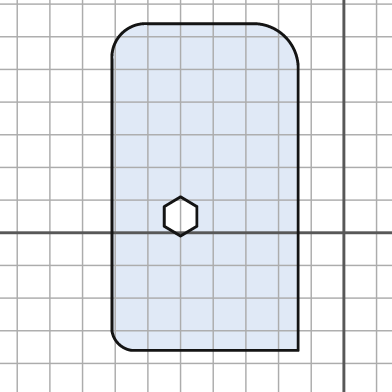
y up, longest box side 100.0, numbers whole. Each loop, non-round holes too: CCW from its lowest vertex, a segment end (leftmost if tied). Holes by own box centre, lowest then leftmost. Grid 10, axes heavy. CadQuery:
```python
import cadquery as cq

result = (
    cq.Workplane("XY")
    .moveTo(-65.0, -36.0)
    .lineTo(-14.0, -36.0)
    .lineTo(-14.0, 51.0)
    .threePointArc((-18.0, 60.0), (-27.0, 64.0))
    .lineTo(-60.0, 64.0)
    .threePointArc((-68.0, 61.0), (-71.0, 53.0))
    .lineTo(-71.0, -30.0)
    .threePointArc((-69.0, -34.0), (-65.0, -36.0))
    .close()
    .moveTo(-50.0, -1.0)
    .lineTo(-45.0, 2.0)
    .lineTo(-45.0, 8.0)
    .lineTo(-50.0, 11.0)
    .lineTo(-55.0, 8.0)
    .lineTo(-55.0, 2.0)
    .close()
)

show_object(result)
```